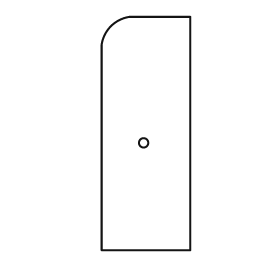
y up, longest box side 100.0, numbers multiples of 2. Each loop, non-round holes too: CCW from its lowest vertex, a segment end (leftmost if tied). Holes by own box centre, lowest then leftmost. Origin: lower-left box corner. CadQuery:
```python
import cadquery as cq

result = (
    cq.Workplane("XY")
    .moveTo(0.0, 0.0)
    .lineTo(38.0, 0.0)
    .lineTo(38.0, 100.0)
    .lineTo(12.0, 100.0)
    .threePointArc((4.0, 96.0), (0.0, 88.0))
    .close()
    .moveTo(18.0, 46.0)
    .circle(2.0)
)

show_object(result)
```